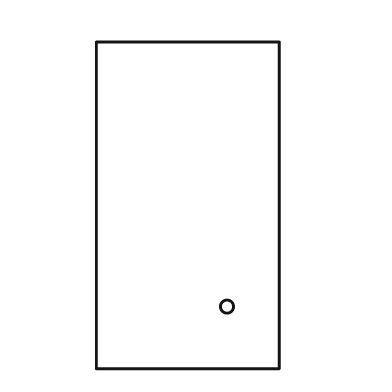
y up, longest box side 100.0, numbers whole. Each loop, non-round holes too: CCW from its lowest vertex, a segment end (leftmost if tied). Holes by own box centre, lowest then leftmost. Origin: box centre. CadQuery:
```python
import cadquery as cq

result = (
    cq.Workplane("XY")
    .moveTo(-28.0, -50.0)
    .lineTo(28.0, -50.0)
    .lineTo(28.0, 50.0)
    .lineTo(-28.0, 50.0)
    .close()
    .moveTo(12.0, -31.0)
    .circle(2.0)
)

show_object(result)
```